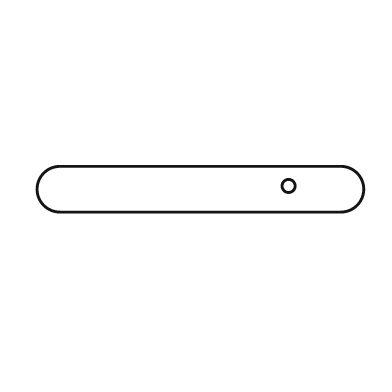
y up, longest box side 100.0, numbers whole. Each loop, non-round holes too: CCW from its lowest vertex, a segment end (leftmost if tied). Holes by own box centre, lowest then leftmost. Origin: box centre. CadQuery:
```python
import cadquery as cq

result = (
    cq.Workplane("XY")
    .moveTo(-43.0, -7.0)
    .lineTo(43.0, -7.0)
    .threePointArc((50.0, 0.0), (43.0, 7.0))
    .lineTo(-43.0, 7.0)
    .threePointArc((-50.0, 0.0), (-43.0, -7.0))
    .close()
    .moveTo(27.0, 1.0)
    .circle(2.0)
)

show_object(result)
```